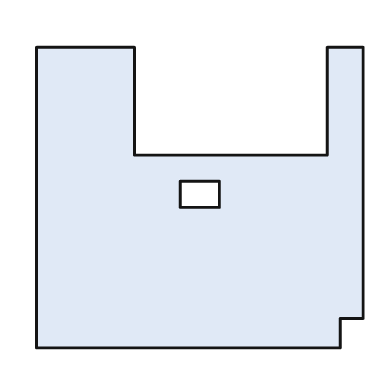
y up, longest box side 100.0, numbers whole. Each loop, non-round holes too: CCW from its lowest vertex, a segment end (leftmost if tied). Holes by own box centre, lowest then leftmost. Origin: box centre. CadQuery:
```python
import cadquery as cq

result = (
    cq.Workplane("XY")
    .moveTo(-50.0, -46.0)
    .lineTo(43.0, -46.0)
    .lineTo(43.0, -37.0)
    .lineTo(50.0, -37.0)
    .lineTo(50.0, 46.0)
    .lineTo(39.0, 46.0)
    .lineTo(39.0, 13.0)
    .lineTo(-20.0, 13.0)
    .lineTo(-20.0, 46.0)
    .lineTo(-50.0, 46.0)
    .close()
    .moveTo(-6.0, -3.0)
    .lineTo(6.0, -3.0)
    .lineTo(6.0, 5.0)
    .lineTo(-6.0, 5.0)
    .close()
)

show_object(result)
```